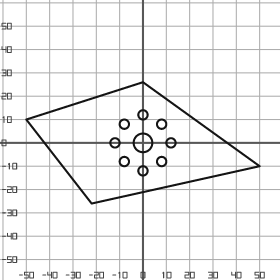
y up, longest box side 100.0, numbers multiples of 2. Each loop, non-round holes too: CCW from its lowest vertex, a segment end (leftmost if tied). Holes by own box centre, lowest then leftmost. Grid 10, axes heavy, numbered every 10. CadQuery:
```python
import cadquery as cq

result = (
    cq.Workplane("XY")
    .moveTo(-22.0, -26.0)
    .lineTo(50.0, -10.0)
    .lineTo(0.0, 26.0)
    .lineTo(-50.0, 10.0)
    .close()
    .moveTo(0.0, -12.0)
    .circle(2.0)
    .moveTo(-8.0, -8.0)
    .circle(2.0)
    .moveTo(8.0, -8.0)
    .circle(2.0)
    .moveTo(-12.0, 0.0)
    .circle(2.0)
    .moveTo(0.0, 0.0)
    .circle(4.0)
    .moveTo(12.0, 0.0)
    .circle(2.0)
    .moveTo(-8.0, 8.0)
    .circle(2.0)
    .moveTo(8.0, 8.0)
    .circle(2.0)
    .moveTo(0.0, 12.0)
    .circle(2.0)
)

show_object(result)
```